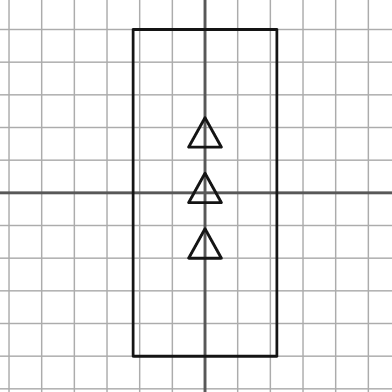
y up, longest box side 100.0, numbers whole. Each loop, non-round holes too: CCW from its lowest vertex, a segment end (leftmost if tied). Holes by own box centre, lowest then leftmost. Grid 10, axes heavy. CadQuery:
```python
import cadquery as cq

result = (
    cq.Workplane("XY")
    .moveTo(-22.0, -50.0)
    .lineTo(22.0, -50.0)
    .lineTo(22.0, 50.0)
    .lineTo(-22.0, 50.0)
    .close()
    .moveTo(-5.0, -20.0)
    .lineTo(5.0, -20.0)
    .lineTo(0.0, -11.0)
    .close()
    .moveTo(-5.0, -3.0)
    .lineTo(5.0, -3.0)
    .lineTo(0.0, 6.0)
    .close()
    .moveTo(-5.0, 14.0)
    .lineTo(5.0, 14.0)
    .lineTo(0.0, 23.0)
    .close()
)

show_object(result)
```